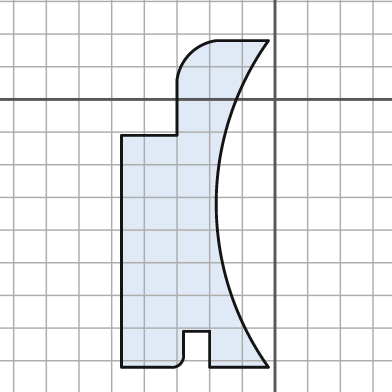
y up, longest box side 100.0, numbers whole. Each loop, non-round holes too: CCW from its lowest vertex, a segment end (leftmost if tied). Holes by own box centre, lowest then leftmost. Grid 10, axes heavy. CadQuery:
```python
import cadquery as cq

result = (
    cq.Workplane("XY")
    .moveTo(-47.0, -82.0)
    .lineTo(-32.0, -82.0)
    .threePointArc((-29.0, -81.0), (-28.0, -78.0))
    .lineTo(-28.0, -71.0)
    .lineTo(-20.0, -71.0)
    .lineTo(-20.0, -82.0)
    .lineTo(-2.0, -82.0)
    .threePointArc((-18.0, -32.0), (-2.0, 18.0))
    .lineTo(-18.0, 18.0)
    .threePointArc((-26.0, 14.0), (-30.0, 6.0))
    .lineTo(-30.0, -11.0)
    .lineTo(-47.0, -11.0)
    .close()
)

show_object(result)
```